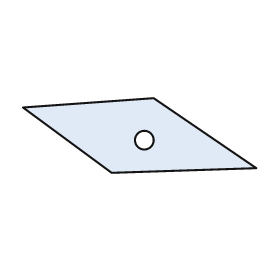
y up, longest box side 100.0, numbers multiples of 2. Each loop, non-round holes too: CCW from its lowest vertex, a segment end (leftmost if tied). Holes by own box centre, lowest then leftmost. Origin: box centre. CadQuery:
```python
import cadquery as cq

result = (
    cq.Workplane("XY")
    .moveTo(-12.0, -16.0)
    .lineTo(50.0, -14.0)
    .lineTo(6.0, 16.0)
    .lineTo(-50.0, 12.0)
    .close()
    .moveTo(2.0, -2.0)
    .circle(4.0)
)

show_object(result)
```